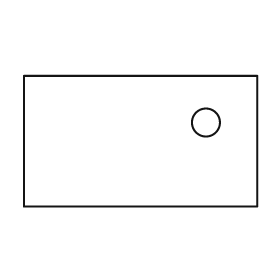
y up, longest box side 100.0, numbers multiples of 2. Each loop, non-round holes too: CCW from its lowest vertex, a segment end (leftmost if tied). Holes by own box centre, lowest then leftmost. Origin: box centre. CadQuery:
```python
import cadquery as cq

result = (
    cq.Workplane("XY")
    .moveTo(-50.0, -28.0)
    .lineTo(50.0, -28.0)
    .lineTo(50.0, 28.0)
    .lineTo(-50.0, 28.0)
    .close()
    .moveTo(28.0, 8.0)
    .circle(6.0)
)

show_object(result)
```